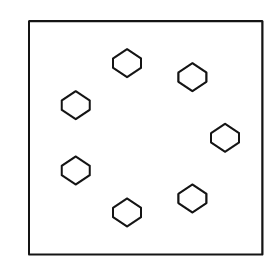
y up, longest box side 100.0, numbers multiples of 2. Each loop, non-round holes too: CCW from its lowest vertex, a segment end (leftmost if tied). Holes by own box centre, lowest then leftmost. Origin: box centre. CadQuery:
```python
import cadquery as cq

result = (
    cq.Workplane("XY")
    .moveTo(-50.0, -50.0)
    .lineTo(50.0, -50.0)
    .lineTo(50.0, 50.0)
    .lineTo(-50.0, 50.0)
    .close()
    .moveTo(-8.0, -38.0)
    .lineTo(-2.0, -34.0)
    .lineTo(-2.0, -30.0)
    .lineTo(-8.0, -26.0)
    .lineTo(-14.0, -30.0)
    .lineTo(-14.0, -34.0)
    .close()
    .moveTo(20.0, -32.0)
    .lineTo(26.0, -28.0)
    .lineTo(26.0, -24.0)
    .lineTo(20.0, -20.0)
    .lineTo(14.0, -24.0)
    .lineTo(14.0, -28.0)
    .close()
    .moveTo(-30.0, -20.0)
    .lineTo(-24.0, -16.0)
    .lineTo(-24.0, -12.0)
    .lineTo(-30.0, -8.0)
    .lineTo(-36.0, -12.0)
    .lineTo(-36.0, -16.0)
    .close()
    .moveTo(34.0, -6.0)
    .lineTo(40.0, -2.0)
    .lineTo(40.0, 2.0)
    .lineTo(34.0, 6.0)
    .lineTo(28.0, 2.0)
    .lineTo(28.0, -2.0)
    .close()
    .moveTo(-30.0, 8.0)
    .lineTo(-24.0, 12.0)
    .lineTo(-24.0, 16.0)
    .lineTo(-30.0, 20.0)
    .lineTo(-36.0, 16.0)
    .lineTo(-36.0, 12.0)
    .close()
    .moveTo(20.0, 20.0)
    .lineTo(26.0, 24.0)
    .lineTo(26.0, 28.0)
    .lineTo(20.0, 32.0)
    .lineTo(14.0, 28.0)
    .lineTo(14.0, 24.0)
    .close()
    .moveTo(-8.0, 26.0)
    .lineTo(-2.0, 30.0)
    .lineTo(-2.0, 34.0)
    .lineTo(-8.0, 38.0)
    .lineTo(-14.0, 34.0)
    .lineTo(-14.0, 30.0)
    .close()
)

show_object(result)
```